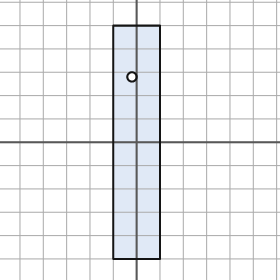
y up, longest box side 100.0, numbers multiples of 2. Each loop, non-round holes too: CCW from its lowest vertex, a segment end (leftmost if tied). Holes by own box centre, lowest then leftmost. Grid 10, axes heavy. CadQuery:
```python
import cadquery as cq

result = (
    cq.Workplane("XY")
    .moveTo(-10.0, -50.0)
    .lineTo(10.0, -50.0)
    .lineTo(10.0, 50.0)
    .lineTo(-10.0, 50.0)
    .close()
    .moveTo(-2.0, 28.0)
    .circle(2.0)
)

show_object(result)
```